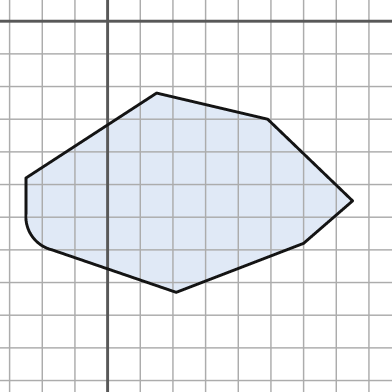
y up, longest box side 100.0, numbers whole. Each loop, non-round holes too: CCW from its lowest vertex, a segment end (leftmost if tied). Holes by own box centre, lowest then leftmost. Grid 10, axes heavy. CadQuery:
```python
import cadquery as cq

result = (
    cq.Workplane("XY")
    .moveTo(21.0, -83.0)
    .lineTo(60.0, -68.0)
    .lineTo(75.0, -55.0)
    .lineTo(49.0, -30.0)
    .lineTo(15.0, -22.0)
    .lineTo(-25.0, -48.0)
    .lineTo(-25.0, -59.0)
    .threePointArc((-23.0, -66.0), (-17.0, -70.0))
    .close()
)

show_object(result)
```